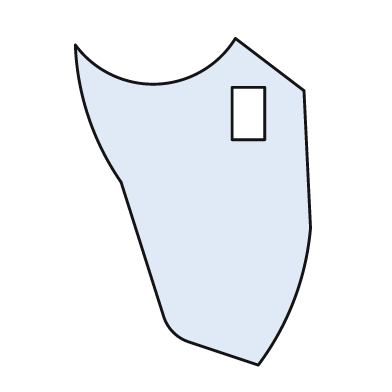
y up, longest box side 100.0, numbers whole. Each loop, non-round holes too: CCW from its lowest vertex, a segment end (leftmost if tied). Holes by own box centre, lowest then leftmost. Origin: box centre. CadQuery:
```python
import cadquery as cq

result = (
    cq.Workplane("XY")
    .moveTo(20.0, -50.0)
    .threePointArc((31.0, -30.0), (36.0, -8.0))
    .lineTo(34.0, 34.0)
    .lineTo(13.0, 50.0)
    .threePointArc((-11.0, 36.0), (-36.0, 48.0))
    .threePointArc((-32.0, 26.0), (-22.0, 6.0))
    .lineTo(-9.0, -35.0)
    .threePointArc((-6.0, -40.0), (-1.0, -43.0))
    .close()
    .moveTo(12.0, 19.0)
    .lineTo(22.0, 19.0)
    .lineTo(22.0, 35.0)
    .lineTo(12.0, 35.0)
    .close()
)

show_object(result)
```